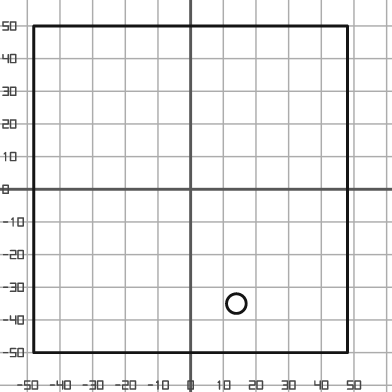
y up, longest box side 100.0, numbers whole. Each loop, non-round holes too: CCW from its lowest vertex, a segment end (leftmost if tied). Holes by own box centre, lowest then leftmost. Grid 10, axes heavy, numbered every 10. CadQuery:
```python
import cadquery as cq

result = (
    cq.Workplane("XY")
    .moveTo(-48.0, -50.0)
    .lineTo(48.0, -50.0)
    .lineTo(48.0, 50.0)
    .lineTo(-48.0, 50.0)
    .close()
    .moveTo(14.0, -35.0)
    .circle(3.0)
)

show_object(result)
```